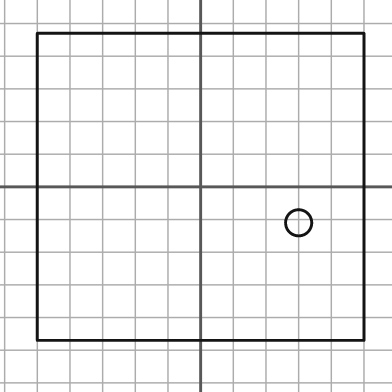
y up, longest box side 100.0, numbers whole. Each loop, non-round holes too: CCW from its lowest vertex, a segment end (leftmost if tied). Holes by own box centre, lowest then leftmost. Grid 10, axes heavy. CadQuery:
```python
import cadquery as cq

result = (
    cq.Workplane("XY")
    .moveTo(-50.0, -47.0)
    .lineTo(50.0, -47.0)
    .lineTo(50.0, 47.0)
    .lineTo(-50.0, 47.0)
    .close()
    .moveTo(30.0, -11.0)
    .circle(4.0)
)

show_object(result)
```